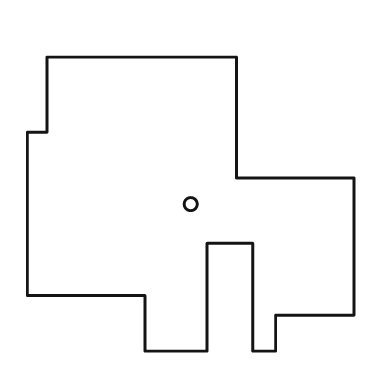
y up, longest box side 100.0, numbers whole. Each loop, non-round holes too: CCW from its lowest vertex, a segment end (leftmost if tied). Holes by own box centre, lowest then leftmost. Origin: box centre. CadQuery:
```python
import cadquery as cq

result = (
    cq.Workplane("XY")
    .moveTo(-14.0, -45.0)
    .lineTo(5.0, -45.0)
    .lineTo(5.0, -12.0)
    .lineTo(19.0, -12.0)
    .lineTo(19.0, -45.0)
    .lineTo(26.0, -45.0)
    .lineTo(26.0, -34.0)
    .lineTo(50.0, -34.0)
    .lineTo(50.0, 8.0)
    .lineTo(14.0, 8.0)
    .lineTo(14.0, 45.0)
    .lineTo(-44.0, 45.0)
    .lineTo(-44.0, 22.0)
    .lineTo(-50.0, 22.0)
    .lineTo(-50.0, -28.0)
    .lineTo(-14.0, -28.0)
    .close()
    .moveTo(0.0, 0.0)
    .circle(2.0)
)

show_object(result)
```